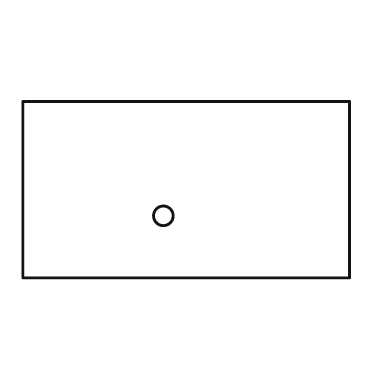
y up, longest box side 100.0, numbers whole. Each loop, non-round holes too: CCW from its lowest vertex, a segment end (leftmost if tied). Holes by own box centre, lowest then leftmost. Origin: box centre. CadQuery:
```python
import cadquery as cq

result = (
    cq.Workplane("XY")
    .moveTo(-50.0, -27.0)
    .lineTo(50.0, -27.0)
    .lineTo(50.0, 27.0)
    .lineTo(-50.0, 27.0)
    .close()
    .moveTo(-7.0, -8.0)
    .circle(3.0)
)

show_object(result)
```